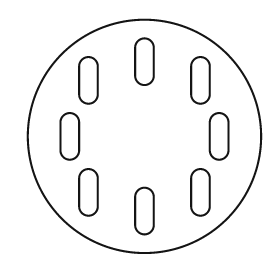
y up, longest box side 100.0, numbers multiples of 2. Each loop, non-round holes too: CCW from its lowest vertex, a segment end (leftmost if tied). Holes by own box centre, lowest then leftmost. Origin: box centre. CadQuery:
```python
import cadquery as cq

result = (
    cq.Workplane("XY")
    .moveTo(0.0, 0.0)
    .circle(50.0)
    .moveTo(-4.0, -38.0)
    .threePointArc((0.0, -42.0), (4.0, -38.0))
    .lineTo(4.0, -26.0)
    .threePointArc((0.0, -22.0), (-4.0, -26.0))
    .close()
    .moveTo(-28.0, -30.0)
    .threePointArc((-24.0, -34.0), (-20.0, -30.0))
    .lineTo(-20.0, -18.0)
    .threePointArc((-24.0, -14.0), (-28.0, -18.0))
    .close()
    .moveTo(20.0, -30.0)
    .threePointArc((24.0, -34.0), (28.0, -30.0))
    .lineTo(28.0, -18.0)
    .threePointArc((24.0, -14.0), (20.0, -18.0))
    .close()
    .moveTo(-36.0, -6.0)
    .threePointArc((-32.0, -10.0), (-28.0, -6.0))
    .lineTo(-28.0, 6.0)
    .threePointArc((-32.0, 10.0), (-36.0, 6.0))
    .close()
    .moveTo(28.0, -6.0)
    .threePointArc((32.0, -10.0), (36.0, -6.0))
    .lineTo(36.0, 6.0)
    .threePointArc((32.0, 10.0), (28.0, 6.0))
    .close()
    .moveTo(-28.0, 18.0)
    .threePointArc((-24.0, 14.0), (-20.0, 18.0))
    .lineTo(-20.0, 30.0)
    .threePointArc((-24.0, 34.0), (-28.0, 30.0))
    .close()
    .moveTo(20.0, 18.0)
    .threePointArc((24.0, 14.0), (28.0, 18.0))
    .lineTo(28.0, 30.0)
    .threePointArc((24.0, 34.0), (20.0, 30.0))
    .close()
    .moveTo(-4.0, 26.0)
    .threePointArc((0.0, 22.0), (4.0, 26.0))
    .lineTo(4.0, 38.0)
    .threePointArc((0.0, 42.0), (-4.0, 38.0))
    .close()
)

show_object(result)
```